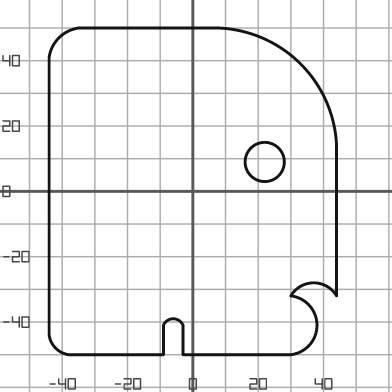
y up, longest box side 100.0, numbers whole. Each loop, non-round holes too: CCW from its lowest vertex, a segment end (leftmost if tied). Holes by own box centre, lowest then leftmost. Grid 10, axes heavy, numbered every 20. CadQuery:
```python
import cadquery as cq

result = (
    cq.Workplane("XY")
    .moveTo(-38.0, -50.0)
    .lineTo(-9.0, -50.0)
    .lineTo(-9.0, -41.0)
    .threePointArc((-6.0, -39.0), (-3.0, -41.0))
    .lineTo(-3.0, -50.0)
    .lineTo(30.0, -50.0)
    .threePointArc((38.0, -41.0), (30.0, -32.0))
    .threePointArc((37.0, -28.0), (44.0, -32.0))
    .lineTo(44.0, 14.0)
    .threePointArc((33.0, 39.0), (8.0, 50.0))
    .lineTo(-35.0, 50.0)
    .threePointArc((-41.0, 47.0), (-44.0, 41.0))
    .lineTo(-44.0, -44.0)
    .threePointArc((-42.0, -48.0), (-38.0, -50.0))
    .close()
    .moveTo(22.0, 9.0)
    .circle(6.0)
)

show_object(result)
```